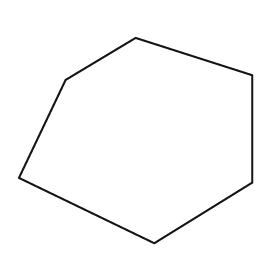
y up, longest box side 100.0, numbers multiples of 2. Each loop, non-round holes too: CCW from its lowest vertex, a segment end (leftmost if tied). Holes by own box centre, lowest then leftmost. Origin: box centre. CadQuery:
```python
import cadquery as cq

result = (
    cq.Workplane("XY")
    .moveTo(8.0, -44.0)
    .lineTo(50.0, -18.0)
    .lineTo(50.0, 28.0)
    .lineTo(0.0, 44.0)
    .lineTo(-30.0, 26.0)
    .lineTo(-50.0, -16.0)
    .close()
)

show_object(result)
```